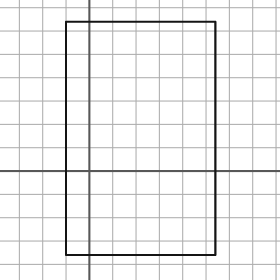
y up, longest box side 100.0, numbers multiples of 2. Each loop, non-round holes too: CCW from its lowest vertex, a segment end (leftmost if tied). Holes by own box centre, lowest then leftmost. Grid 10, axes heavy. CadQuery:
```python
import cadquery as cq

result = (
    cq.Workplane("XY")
    .moveTo(-10.0, -36.0)
    .lineTo(54.0, -36.0)
    .lineTo(54.0, 64.0)
    .lineTo(-10.0, 64.0)
    .close()
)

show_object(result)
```